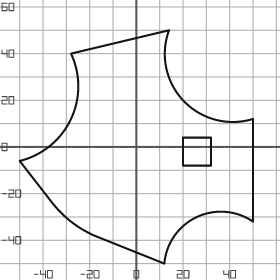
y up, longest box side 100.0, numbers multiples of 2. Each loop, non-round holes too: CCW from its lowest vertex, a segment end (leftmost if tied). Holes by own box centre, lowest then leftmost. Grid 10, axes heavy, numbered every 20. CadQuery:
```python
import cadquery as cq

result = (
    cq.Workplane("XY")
    .moveTo(12.0, -50.0)
    .threePointArc((26.0, -30.0), (50.0, -32.0))
    .lineTo(50.0, 12.0)
    .threePointArc((20.0, 20.0), (14.0, 50.0))
    .lineTo(-28.0, 40.0)
    .threePointArc((-28.0, 12.0), (-50.0, -6.0))
    .lineTo(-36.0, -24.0)
    .threePointArc((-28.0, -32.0), (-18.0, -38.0))
    .close()
    .moveTo(20.0, -8.0)
    .lineTo(32.0, -8.0)
    .lineTo(32.0, 4.0)
    .lineTo(20.0, 4.0)
    .close()
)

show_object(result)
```